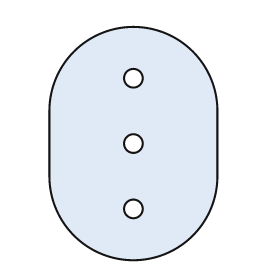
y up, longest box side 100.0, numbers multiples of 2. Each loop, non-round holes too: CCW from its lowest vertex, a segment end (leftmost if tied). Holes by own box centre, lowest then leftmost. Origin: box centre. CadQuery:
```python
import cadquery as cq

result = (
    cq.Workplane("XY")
    .moveTo(-36.0, -14.0)
    .threePointArc((0.0, -50.0), (36.0, -14.0))
    .lineTo(36.0, 14.0)
    .threePointArc((0.0, 50.0), (-36.0, 14.0))
    .close()
    .moveTo(0.0, -28.0)
    .circle(4.0)
    .moveTo(0.0, 0.0)
    .circle(4.0)
    .moveTo(0.0, 28.0)
    .circle(4.0)
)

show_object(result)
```